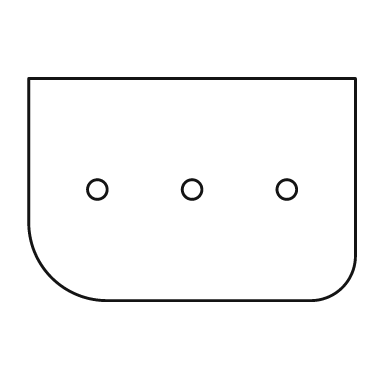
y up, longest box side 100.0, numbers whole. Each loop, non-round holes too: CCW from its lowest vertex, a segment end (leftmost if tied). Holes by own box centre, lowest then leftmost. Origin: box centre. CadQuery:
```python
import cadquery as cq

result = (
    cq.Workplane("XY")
    .moveTo(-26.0, -34.0)
    .lineTo(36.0, -34.0)
    .threePointArc((46.0, -30.0), (50.0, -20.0))
    .lineTo(50.0, 34.0)
    .lineTo(-50.0, 34.0)
    .lineTo(-50.0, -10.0)
    .threePointArc((-43.0, -27.0), (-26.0, -34.0))
    .close()
    .moveTo(-29.0, 0.0)
    .circle(3.0)
    .moveTo(0.0, 0.0)
    .circle(3.0)
    .moveTo(29.0, 0.0)
    .circle(3.0)
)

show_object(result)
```